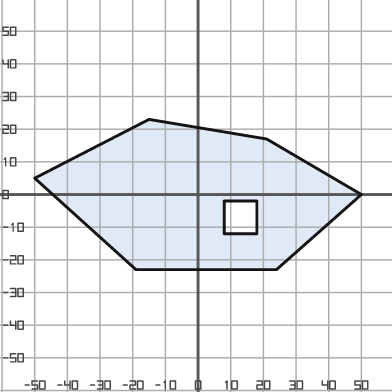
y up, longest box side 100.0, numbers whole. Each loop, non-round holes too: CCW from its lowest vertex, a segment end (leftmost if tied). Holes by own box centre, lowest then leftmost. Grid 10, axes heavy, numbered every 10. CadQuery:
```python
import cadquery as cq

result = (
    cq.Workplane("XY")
    .moveTo(-19.0, -23.0)
    .lineTo(24.0, -23.0)
    .lineTo(50.0, 0.0)
    .lineTo(21.0, 17.0)
    .lineTo(-15.0, 23.0)
    .lineTo(-50.0, 5.0)
    .close()
    .moveTo(8.0, -12.0)
    .lineTo(18.0, -12.0)
    .lineTo(18.0, -2.0)
    .lineTo(8.0, -2.0)
    .close()
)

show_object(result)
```